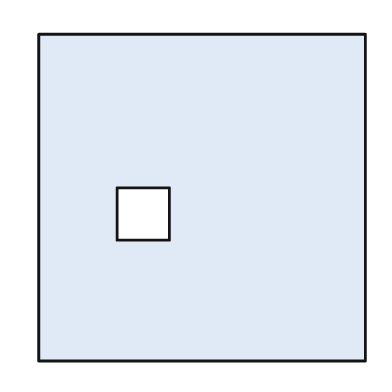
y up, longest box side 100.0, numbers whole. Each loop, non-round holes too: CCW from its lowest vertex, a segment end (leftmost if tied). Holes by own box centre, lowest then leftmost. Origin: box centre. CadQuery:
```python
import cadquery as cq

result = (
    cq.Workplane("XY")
    .moveTo(-50.0, -50.0)
    .lineTo(50.0, -50.0)
    .lineTo(50.0, 50.0)
    .lineTo(-50.0, 50.0)
    .close()
    .moveTo(-26.0, -13.0)
    .lineTo(-10.0, -13.0)
    .lineTo(-10.0, 3.0)
    .lineTo(-26.0, 3.0)
    .close()
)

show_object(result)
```